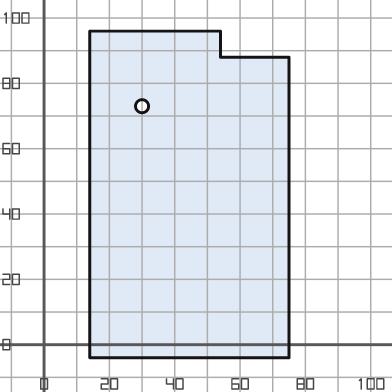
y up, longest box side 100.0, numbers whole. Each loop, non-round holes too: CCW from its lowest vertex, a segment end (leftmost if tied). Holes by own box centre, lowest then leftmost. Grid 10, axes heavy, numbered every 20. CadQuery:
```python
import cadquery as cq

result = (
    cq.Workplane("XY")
    .moveTo(14.0, -4.0)
    .lineTo(75.0, -4.0)
    .lineTo(75.0, 88.0)
    .lineTo(54.0, 88.0)
    .lineTo(54.0, 96.0)
    .lineTo(14.0, 96.0)
    .close()
    .moveTo(30.0, 73.0)
    .circle(2.0)
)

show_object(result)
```